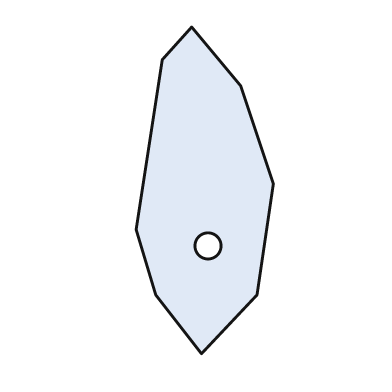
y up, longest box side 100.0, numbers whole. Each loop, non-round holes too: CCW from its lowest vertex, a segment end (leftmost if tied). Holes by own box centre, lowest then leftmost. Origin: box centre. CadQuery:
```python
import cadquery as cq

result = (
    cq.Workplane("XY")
    .moveTo(-1.0, -50.0)
    .lineTo(16.0, -32.0)
    .lineTo(21.0, 2.0)
    .lineTo(11.0, 32.0)
    .lineTo(-4.0, 50.0)
    .lineTo(-13.0, 40.0)
    .lineTo(-21.0, -12.0)
    .lineTo(-15.0, -32.0)
    .close()
    .moveTo(1.0, -17.0)
    .circle(4.0)
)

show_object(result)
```